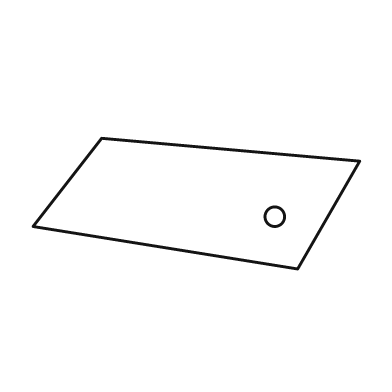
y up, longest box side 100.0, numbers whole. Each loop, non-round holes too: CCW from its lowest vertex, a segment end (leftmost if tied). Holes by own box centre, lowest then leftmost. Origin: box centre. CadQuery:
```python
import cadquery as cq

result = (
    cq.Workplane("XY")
    .moveTo(31.0, -20.0)
    .lineTo(50.0, 13.0)
    .lineTo(-29.0, 20.0)
    .lineTo(-50.0, -7.0)
    .close()
    .moveTo(24.0, -4.0)
    .circle(3.0)
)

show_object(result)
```